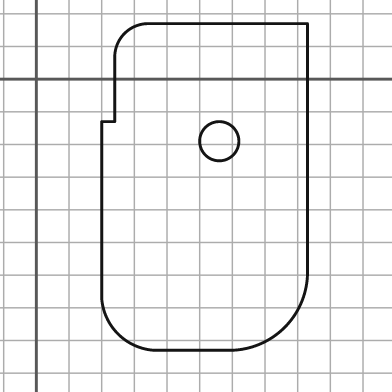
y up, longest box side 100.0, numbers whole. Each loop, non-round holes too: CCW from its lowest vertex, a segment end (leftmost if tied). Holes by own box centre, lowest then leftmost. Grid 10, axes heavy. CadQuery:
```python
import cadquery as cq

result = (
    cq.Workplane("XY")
    .moveTo(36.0, -83.0)
    .lineTo(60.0, -83.0)
    .threePointArc((76.0, -76.0), (83.0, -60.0))
    .lineTo(83.0, 17.0)
    .lineTo(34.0, 17.0)
    .threePointArc((27.0, 14.0), (24.0, 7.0))
    .lineTo(24.0, -13.0)
    .lineTo(20.0, -13.0)
    .lineTo(20.0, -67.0)
    .threePointArc((25.0, -78.0), (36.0, -83.0))
    .close()
    .moveTo(56.0, -19.0)
    .circle(6.0)
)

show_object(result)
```